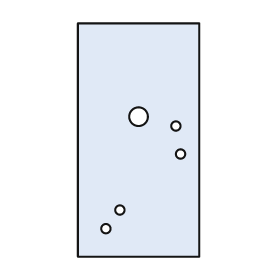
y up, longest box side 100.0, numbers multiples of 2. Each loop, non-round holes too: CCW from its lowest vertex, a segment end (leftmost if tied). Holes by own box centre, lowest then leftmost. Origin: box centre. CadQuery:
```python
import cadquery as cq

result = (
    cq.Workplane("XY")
    .moveTo(-26.0, -50.0)
    .lineTo(26.0, -50.0)
    .lineTo(26.0, 50.0)
    .lineTo(-26.0, 50.0)
    .close()
    .moveTo(-14.0, -38.0)
    .circle(2.0)
    .moveTo(-8.0, -30.0)
    .circle(2.0)
    .moveTo(18.0, -6.0)
    .circle(2.0)
    .moveTo(16.0, 6.0)
    .circle(2.0)
    .moveTo(0.0, 10.0)
    .circle(4.0)
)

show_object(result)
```